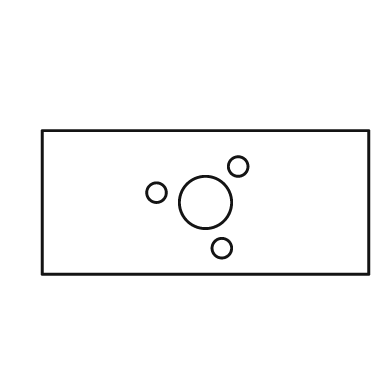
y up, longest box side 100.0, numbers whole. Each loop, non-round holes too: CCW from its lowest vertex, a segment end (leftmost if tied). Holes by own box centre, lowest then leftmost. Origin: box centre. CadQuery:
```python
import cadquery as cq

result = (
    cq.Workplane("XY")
    .moveTo(-50.0, -22.0)
    .lineTo(50.0, -22.0)
    .lineTo(50.0, 22.0)
    .lineTo(-50.0, 22.0)
    .close()
    .moveTo(5.0, -14.0)
    .circle(3.0)
    .moveTo(0.0, 0.0)
    .circle(8.0)
    .moveTo(-15.0, 3.0)
    .circle(3.0)
    .moveTo(10.0, 11.0)
    .circle(3.0)
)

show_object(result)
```